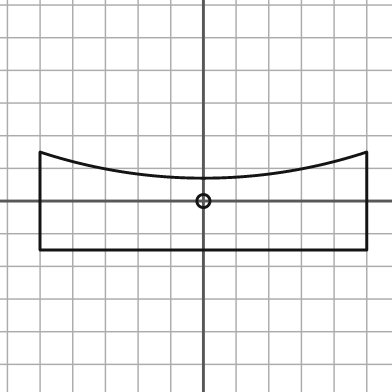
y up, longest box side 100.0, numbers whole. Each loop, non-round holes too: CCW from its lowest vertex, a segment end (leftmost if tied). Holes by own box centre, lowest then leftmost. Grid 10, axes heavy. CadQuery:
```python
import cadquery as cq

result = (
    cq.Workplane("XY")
    .moveTo(-50.0, -15.0)
    .lineTo(50.0, -15.0)
    .lineTo(50.0, 15.0)
    .threePointArc((0.0, 7.0), (-50.0, 15.0))
    .close()
    .moveTo(0.0, 0.0)
    .circle(2.0)
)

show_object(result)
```